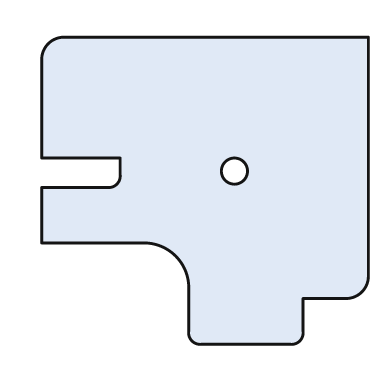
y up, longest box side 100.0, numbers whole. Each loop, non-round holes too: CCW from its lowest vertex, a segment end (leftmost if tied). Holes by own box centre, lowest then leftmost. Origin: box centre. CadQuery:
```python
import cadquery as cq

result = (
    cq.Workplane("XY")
    .moveTo(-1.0, -47.0)
    .lineTo(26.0, -47.0)
    .threePointArc((29.0, -46.0), (30.0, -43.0))
    .lineTo(30.0, -33.0)
    .lineTo(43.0, -33.0)
    .threePointArc((48.0, -31.0), (50.0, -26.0))
    .lineTo(50.0, 47.0)
    .lineTo(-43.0, 47.0)
    .threePointArc((-48.0, 45.0), (-50.0, 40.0))
    .lineTo(-50.0, 10.0)
    .lineTo(-26.0, 10.0)
    .lineTo(-26.0, 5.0)
    .threePointArc((-27.0, 2.0), (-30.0, 1.0))
    .lineTo(-50.0, 1.0)
    .lineTo(-50.0, -16.0)
    .lineTo(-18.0, -16.0)
    .threePointArc((-9.0, -20.0), (-5.0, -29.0))
    .lineTo(-5.0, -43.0)
    .threePointArc((-4.0, -46.0), (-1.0, -47.0))
    .close()
    .moveTo(9.0, 6.0)
    .circle(4.0)
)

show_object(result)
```